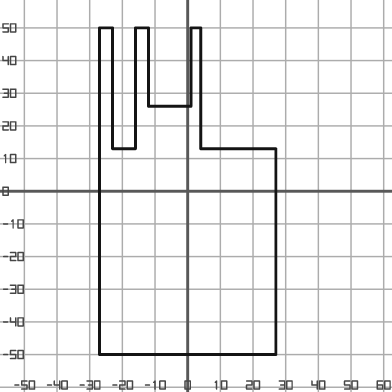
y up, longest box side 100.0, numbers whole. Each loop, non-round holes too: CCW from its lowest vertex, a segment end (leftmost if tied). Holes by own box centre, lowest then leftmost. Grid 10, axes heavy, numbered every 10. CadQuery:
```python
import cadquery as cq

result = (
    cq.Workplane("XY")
    .moveTo(-27.0, -50.0)
    .lineTo(27.0, -50.0)
    .lineTo(27.0, 13.0)
    .lineTo(4.0, 13.0)
    .lineTo(4.0, 50.0)
    .lineTo(1.0, 50.0)
    .lineTo(1.0, 26.0)
    .lineTo(-12.0, 26.0)
    .lineTo(-12.0, 50.0)
    .lineTo(-16.0, 50.0)
    .lineTo(-16.0, 13.0)
    .lineTo(-23.0, 13.0)
    .lineTo(-23.0, 50.0)
    .lineTo(-27.0, 50.0)
    .close()
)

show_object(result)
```